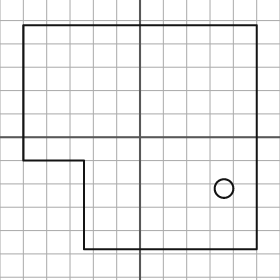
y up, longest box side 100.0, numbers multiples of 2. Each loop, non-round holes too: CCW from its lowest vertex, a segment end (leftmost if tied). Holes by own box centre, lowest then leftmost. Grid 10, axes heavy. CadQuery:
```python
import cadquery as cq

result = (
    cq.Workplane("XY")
    .moveTo(-24.0, -48.0)
    .lineTo(50.0, -48.0)
    .lineTo(50.0, 48.0)
    .lineTo(-50.0, 48.0)
    .lineTo(-50.0, -10.0)
    .lineTo(-24.0, -10.0)
    .close()
    .moveTo(36.0, -22.0)
    .circle(4.0)
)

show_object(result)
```